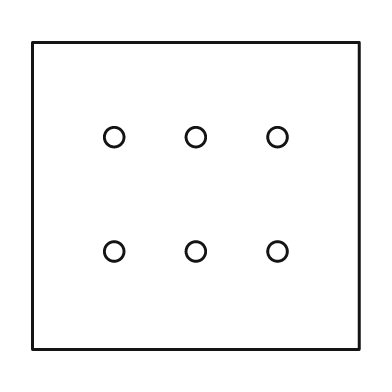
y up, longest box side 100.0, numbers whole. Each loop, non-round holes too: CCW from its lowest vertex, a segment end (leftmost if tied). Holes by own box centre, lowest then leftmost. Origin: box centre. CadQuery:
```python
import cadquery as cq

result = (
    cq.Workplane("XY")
    .moveTo(-50.0, -47.0)
    .lineTo(50.0, -47.0)
    .lineTo(50.0, 47.0)
    .lineTo(-50.0, 47.0)
    .close()
    .moveTo(-25.0, -17.0)
    .circle(3.0)
    .moveTo(0.0, -17.0)
    .circle(3.0)
    .moveTo(25.0, -17.0)
    .circle(3.0)
    .moveTo(-25.0, 18.0)
    .circle(3.0)
    .moveTo(0.0, 18.0)
    .circle(3.0)
    .moveTo(25.0, 18.0)
    .circle(3.0)
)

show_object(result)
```